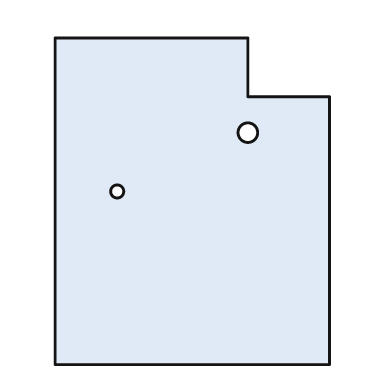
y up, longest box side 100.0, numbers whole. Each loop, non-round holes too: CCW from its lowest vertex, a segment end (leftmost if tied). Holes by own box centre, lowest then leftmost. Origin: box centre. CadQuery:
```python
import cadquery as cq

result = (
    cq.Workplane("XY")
    .moveTo(-42.0, -50.0)
    .lineTo(42.0, -50.0)
    .lineTo(42.0, 32.0)
    .lineTo(17.0, 32.0)
    .lineTo(17.0, 50.0)
    .lineTo(-42.0, 50.0)
    .close()
    .moveTo(-23.0, 3.0)
    .circle(2.0)
    .moveTo(17.0, 21.0)
    .circle(3.0)
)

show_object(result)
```